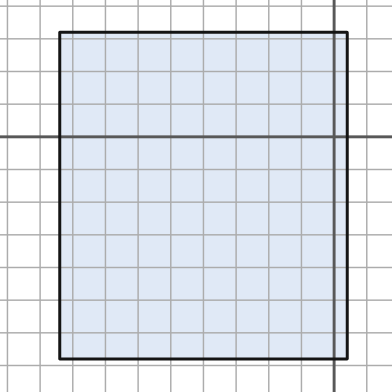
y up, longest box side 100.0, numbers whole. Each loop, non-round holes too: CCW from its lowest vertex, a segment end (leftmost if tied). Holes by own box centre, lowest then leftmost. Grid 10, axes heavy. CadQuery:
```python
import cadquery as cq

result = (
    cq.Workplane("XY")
    .moveTo(-84.0, -68.0)
    .lineTo(4.0, -68.0)
    .lineTo(4.0, 32.0)
    .lineTo(-84.0, 32.0)
    .close()
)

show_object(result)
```